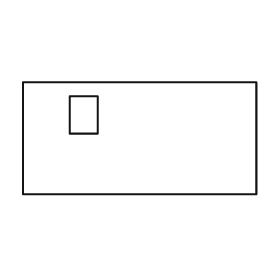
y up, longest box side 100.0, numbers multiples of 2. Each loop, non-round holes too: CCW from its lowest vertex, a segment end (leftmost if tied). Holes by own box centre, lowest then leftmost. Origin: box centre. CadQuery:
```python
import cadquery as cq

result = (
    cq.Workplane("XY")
    .moveTo(-50.0, -24.0)
    .lineTo(50.0, -24.0)
    .lineTo(50.0, 24.0)
    .lineTo(-50.0, 24.0)
    .close()
    .moveTo(-30.0, 2.0)
    .lineTo(-18.0, 2.0)
    .lineTo(-18.0, 18.0)
    .lineTo(-30.0, 18.0)
    .close()
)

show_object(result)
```